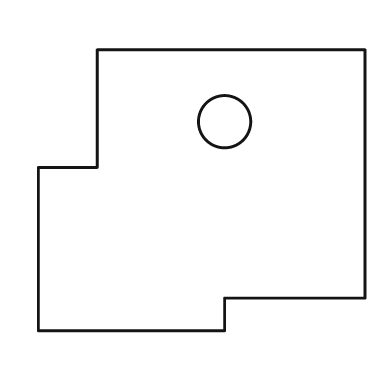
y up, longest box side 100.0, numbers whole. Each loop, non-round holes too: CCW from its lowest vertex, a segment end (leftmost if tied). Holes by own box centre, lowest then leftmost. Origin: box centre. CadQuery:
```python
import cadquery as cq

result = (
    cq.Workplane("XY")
    .moveTo(-50.0, -43.0)
    .lineTo(7.0, -43.0)
    .lineTo(7.0, -33.0)
    .lineTo(50.0, -33.0)
    .lineTo(50.0, 43.0)
    .lineTo(-32.0, 43.0)
    .lineTo(-32.0, 7.0)
    .lineTo(-50.0, 7.0)
    .close()
    .moveTo(7.0, 21.0)
    .circle(8.0)
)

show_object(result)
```